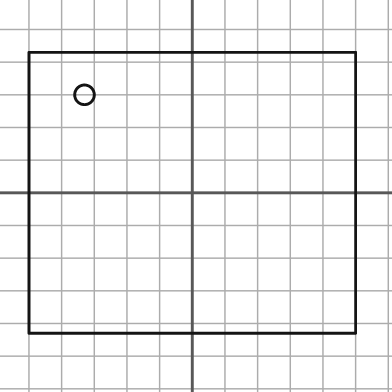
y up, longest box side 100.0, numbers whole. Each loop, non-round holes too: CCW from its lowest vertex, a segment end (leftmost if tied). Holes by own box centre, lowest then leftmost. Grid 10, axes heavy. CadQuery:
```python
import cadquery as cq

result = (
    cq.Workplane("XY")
    .moveTo(-50.0, -43.0)
    .lineTo(50.0, -43.0)
    .lineTo(50.0, 43.0)
    .lineTo(-50.0, 43.0)
    .close()
    .moveTo(-33.0, 30.0)
    .circle(3.0)
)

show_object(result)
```